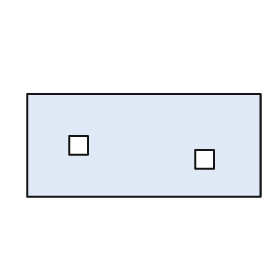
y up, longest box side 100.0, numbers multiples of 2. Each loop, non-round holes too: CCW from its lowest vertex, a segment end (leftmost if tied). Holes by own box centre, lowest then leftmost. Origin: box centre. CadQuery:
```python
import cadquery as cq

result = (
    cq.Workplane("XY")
    .moveTo(-50.0, -22.0)
    .lineTo(50.0, -22.0)
    .lineTo(50.0, 22.0)
    .lineTo(-50.0, 22.0)
    .close()
    .moveTo(22.0, -10.0)
    .lineTo(30.0, -10.0)
    .lineTo(30.0, -2.0)
    .lineTo(22.0, -2.0)
    .close()
    .moveTo(-32.0, -4.0)
    .lineTo(-24.0, -4.0)
    .lineTo(-24.0, 4.0)
    .lineTo(-32.0, 4.0)
    .close()
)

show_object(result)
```